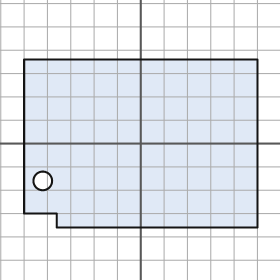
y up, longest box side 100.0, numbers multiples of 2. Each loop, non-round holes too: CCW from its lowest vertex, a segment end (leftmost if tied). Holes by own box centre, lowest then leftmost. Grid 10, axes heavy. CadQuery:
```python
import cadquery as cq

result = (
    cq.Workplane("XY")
    .moveTo(-36.0, -36.0)
    .lineTo(50.0, -36.0)
    .lineTo(50.0, 36.0)
    .lineTo(-50.0, 36.0)
    .lineTo(-50.0, -30.0)
    .lineTo(-36.0, -30.0)
    .close()
    .moveTo(-42.0, -16.0)
    .circle(4.0)
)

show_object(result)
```